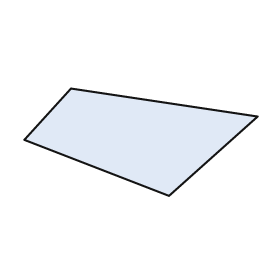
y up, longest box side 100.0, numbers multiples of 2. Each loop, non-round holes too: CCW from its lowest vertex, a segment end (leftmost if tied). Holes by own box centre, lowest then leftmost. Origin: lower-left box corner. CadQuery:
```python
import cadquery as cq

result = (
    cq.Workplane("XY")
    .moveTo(62.0, 0.0)
    .lineTo(100.0, 34.0)
    .lineTo(20.0, 46.0)
    .lineTo(0.0, 24.0)
    .close()
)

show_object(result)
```